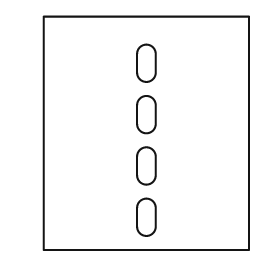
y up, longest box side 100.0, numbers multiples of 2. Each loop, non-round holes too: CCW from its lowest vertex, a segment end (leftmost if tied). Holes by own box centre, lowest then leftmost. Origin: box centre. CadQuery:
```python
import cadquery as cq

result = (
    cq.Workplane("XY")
    .moveTo(-44.0, -50.0)
    .lineTo(44.0, -50.0)
    .lineTo(44.0, 50.0)
    .lineTo(-44.0, 50.0)
    .close()
    .moveTo(-4.0, -40.0)
    .threePointArc((0.0, -44.0), (4.0, -40.0))
    .lineTo(4.0, -32.0)
    .threePointArc((0.0, -28.0), (-4.0, -32.0))
    .close()
    .moveTo(-4.0, -18.0)
    .threePointArc((0.0, -22.0), (4.0, -18.0))
    .lineTo(4.0, -10.0)
    .threePointArc((0.0, -6.0), (-4.0, -10.0))
    .close()
    .moveTo(-4.0, 4.0)
    .threePointArc((0.0, 0.0), (4.0, 4.0))
    .lineTo(4.0, 12.0)
    .threePointArc((0.0, 16.0), (-4.0, 12.0))
    .close()
    .moveTo(-4.0, 26.0)
    .threePointArc((0.0, 22.0), (4.0, 26.0))
    .lineTo(4.0, 34.0)
    .threePointArc((0.0, 38.0), (-4.0, 34.0))
    .close()
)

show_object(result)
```